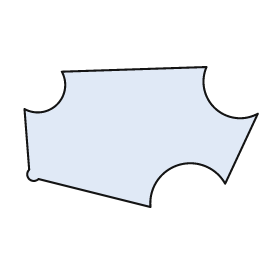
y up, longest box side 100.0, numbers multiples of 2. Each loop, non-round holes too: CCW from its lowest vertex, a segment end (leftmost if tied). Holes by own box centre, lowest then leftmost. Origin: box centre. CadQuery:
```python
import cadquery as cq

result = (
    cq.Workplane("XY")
    .moveTo(4.0, -30.0)
    .threePointArc((16.0, -12.0), (36.0, -20.0))
    .lineTo(50.0, 10.0)
    .threePointArc((32.0, 12.0), (28.0, 30.0))
    .lineTo(-34.0, 28.0)
    .threePointArc((-36.0, 14.0), (-50.0, 12.0))
    .lineTo(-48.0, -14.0)
    .threePointArc((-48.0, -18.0), (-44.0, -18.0))
    .close()
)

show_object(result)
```